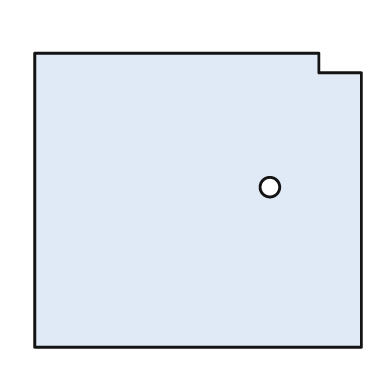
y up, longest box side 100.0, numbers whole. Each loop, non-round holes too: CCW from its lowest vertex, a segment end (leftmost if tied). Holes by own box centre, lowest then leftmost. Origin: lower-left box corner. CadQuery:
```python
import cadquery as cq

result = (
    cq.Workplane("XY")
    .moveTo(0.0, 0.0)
    .lineTo(100.0, 0.0)
    .lineTo(100.0, 84.0)
    .lineTo(87.0, 84.0)
    .lineTo(87.0, 90.0)
    .lineTo(0.0, 90.0)
    .close()
    .moveTo(72.0, 49.0)
    .circle(3.0)
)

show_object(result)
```